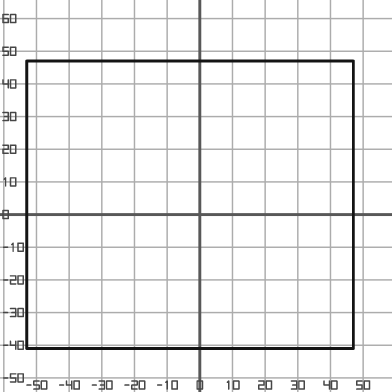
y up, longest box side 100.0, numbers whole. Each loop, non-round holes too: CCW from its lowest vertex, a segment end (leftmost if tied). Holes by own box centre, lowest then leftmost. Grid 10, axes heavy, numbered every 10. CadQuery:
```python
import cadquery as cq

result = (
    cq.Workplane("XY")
    .moveTo(-53.0, -41.0)
    .lineTo(47.0, -41.0)
    .lineTo(47.0, 47.0)
    .lineTo(-53.0, 47.0)
    .close()
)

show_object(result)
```